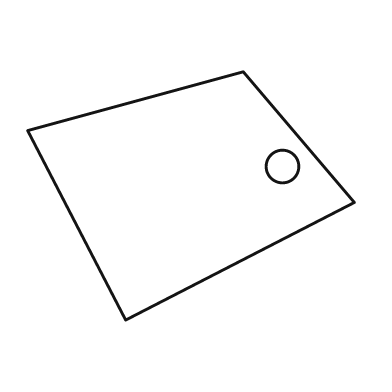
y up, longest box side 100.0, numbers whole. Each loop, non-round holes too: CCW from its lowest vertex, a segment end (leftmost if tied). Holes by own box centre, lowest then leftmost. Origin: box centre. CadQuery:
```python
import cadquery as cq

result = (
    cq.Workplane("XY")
    .moveTo(-20.0, -38.0)
    .lineTo(50.0, -2.0)
    .lineTo(16.0, 38.0)
    .lineTo(-50.0, 20.0)
    .close()
    .moveTo(28.0, 9.0)
    .circle(5.0)
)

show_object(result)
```